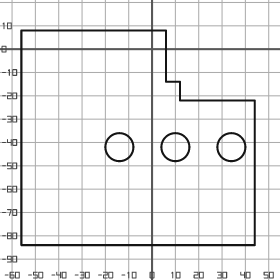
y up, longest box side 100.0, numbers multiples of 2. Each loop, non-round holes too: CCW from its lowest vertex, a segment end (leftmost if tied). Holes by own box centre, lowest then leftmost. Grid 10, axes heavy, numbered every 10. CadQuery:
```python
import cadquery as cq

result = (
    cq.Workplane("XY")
    .moveTo(-56.0, -84.0)
    .lineTo(44.0, -84.0)
    .lineTo(44.0, -22.0)
    .lineTo(12.0, -22.0)
    .lineTo(12.0, -14.0)
    .lineTo(6.0, -14.0)
    .lineTo(6.0, 8.0)
    .lineTo(-56.0, 8.0)
    .close()
    .moveTo(-14.0, -42.0)
    .circle(6.0)
    .moveTo(10.0, -42.0)
    .circle(6.0)
    .moveTo(34.0, -42.0)
    .circle(6.0)
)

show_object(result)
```